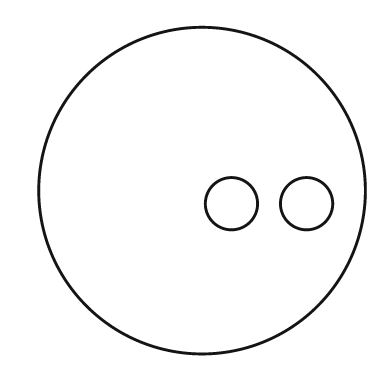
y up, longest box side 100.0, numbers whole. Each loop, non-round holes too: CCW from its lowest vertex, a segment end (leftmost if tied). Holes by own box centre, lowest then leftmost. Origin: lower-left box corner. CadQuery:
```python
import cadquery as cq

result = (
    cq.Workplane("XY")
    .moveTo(50.0, 50.0)
    .circle(50.0)
    .moveTo(59.0, 46.0)
    .circle(8.0)
    .moveTo(82.0, 46.0)
    .circle(8.0)
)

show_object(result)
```